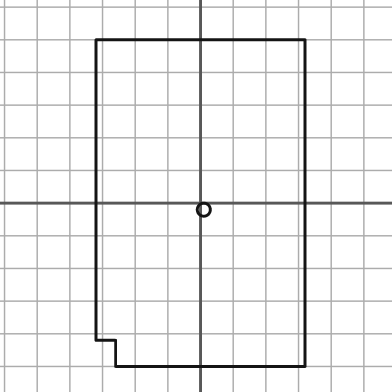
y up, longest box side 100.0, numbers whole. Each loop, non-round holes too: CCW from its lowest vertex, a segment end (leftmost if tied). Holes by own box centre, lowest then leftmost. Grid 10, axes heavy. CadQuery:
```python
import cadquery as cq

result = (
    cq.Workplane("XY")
    .moveTo(-26.0, -50.0)
    .lineTo(32.0, -50.0)
    .lineTo(32.0, 50.0)
    .lineTo(-32.0, 50.0)
    .lineTo(-32.0, -42.0)
    .lineTo(-26.0, -42.0)
    .close()
    .moveTo(1.0, -2.0)
    .circle(2.0)
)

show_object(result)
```